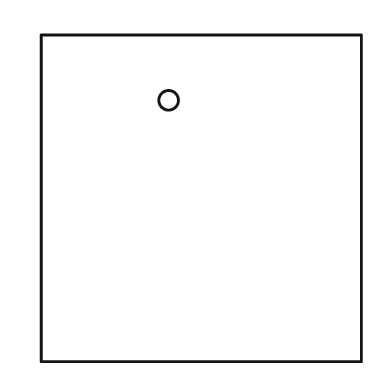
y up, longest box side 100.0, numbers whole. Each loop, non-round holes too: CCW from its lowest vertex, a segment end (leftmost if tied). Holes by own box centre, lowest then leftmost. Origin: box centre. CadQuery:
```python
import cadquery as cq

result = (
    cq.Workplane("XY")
    .moveTo(-49.0, -50.0)
    .lineTo(49.0, -50.0)
    .lineTo(49.0, 50.0)
    .lineTo(-49.0, 50.0)
    .close()
    .moveTo(-10.0, 30.0)
    .circle(3.0)
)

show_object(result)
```